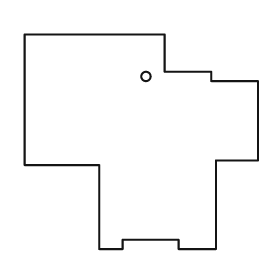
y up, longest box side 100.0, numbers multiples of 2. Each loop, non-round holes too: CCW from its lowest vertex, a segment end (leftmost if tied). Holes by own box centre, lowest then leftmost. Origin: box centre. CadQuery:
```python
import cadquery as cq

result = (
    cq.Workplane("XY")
    .moveTo(-18.0, -46.0)
    .lineTo(-8.0, -46.0)
    .lineTo(-8.0, -42.0)
    .lineTo(16.0, -42.0)
    .lineTo(16.0, -46.0)
    .lineTo(32.0, -46.0)
    .lineTo(32.0, -8.0)
    .lineTo(50.0, -8.0)
    .lineTo(50.0, 26.0)
    .lineTo(30.0, 26.0)
    .lineTo(30.0, 30.0)
    .lineTo(10.0, 30.0)
    .lineTo(10.0, 46.0)
    .lineTo(-50.0, 46.0)
    .lineTo(-50.0, -10.0)
    .lineTo(-18.0, -10.0)
    .close()
    .moveTo(2.0, 28.0)
    .circle(2.0)
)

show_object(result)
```